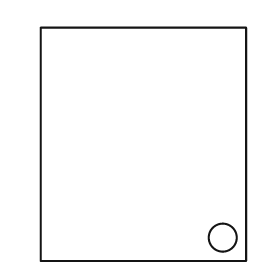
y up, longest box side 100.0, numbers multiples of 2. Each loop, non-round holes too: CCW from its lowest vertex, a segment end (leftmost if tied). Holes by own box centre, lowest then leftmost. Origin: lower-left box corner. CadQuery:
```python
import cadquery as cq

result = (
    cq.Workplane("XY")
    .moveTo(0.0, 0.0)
    .lineTo(88.0, 0.0)
    .lineTo(88.0, 100.0)
    .lineTo(0.0, 100.0)
    .close()
    .moveTo(78.0, 10.0)
    .circle(6.0)
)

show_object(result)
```